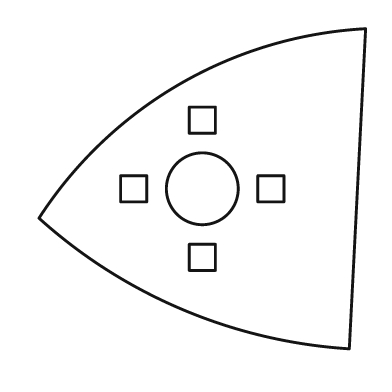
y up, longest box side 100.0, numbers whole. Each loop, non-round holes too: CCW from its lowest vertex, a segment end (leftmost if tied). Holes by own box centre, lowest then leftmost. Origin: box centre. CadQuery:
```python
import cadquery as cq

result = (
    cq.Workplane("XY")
    .moveTo(45.0, -49.0)
    .lineTo(50.0, 49.0)
    .threePointArc((-7.0, 32.0), (-50.0, -9.0))
    .threePointArc((-6.0, -37.0), (45.0, -49.0))
    .close()
    .moveTo(-4.0, -25.0)
    .lineTo(4.0, -25.0)
    .lineTo(4.0, -17.0)
    .lineTo(-4.0, -17.0)
    .close()
    .moveTo(-25.0, -4.0)
    .lineTo(-17.0, -4.0)
    .lineTo(-17.0, 4.0)
    .lineTo(-25.0, 4.0)
    .close()
    .moveTo(0.0, 0.0)
    .circle(11.0)
    .moveTo(17.0, -4.0)
    .lineTo(25.0, -4.0)
    .lineTo(25.0, 4.0)
    .lineTo(17.0, 4.0)
    .close()
    .moveTo(-4.0, 17.0)
    .lineTo(4.0, 17.0)
    .lineTo(4.0, 25.0)
    .lineTo(-4.0, 25.0)
    .close()
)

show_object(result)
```